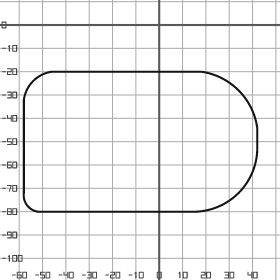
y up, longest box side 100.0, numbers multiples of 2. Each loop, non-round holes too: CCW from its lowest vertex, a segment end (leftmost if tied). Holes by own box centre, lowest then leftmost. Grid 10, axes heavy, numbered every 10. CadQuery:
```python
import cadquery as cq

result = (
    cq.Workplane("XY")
    .moveTo(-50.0, -80.0)
    .lineTo(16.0, -80.0)
    .threePointArc((34.0, -72.0), (42.0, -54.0))
    .lineTo(42.0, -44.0)
    .threePointArc((34.0, -28.0), (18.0, -20.0))
    .lineTo(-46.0, -20.0)
    .threePointArc((-54.0, -24.0), (-58.0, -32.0))
    .lineTo(-58.0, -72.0)
    .threePointArc((-56.0, -78.0), (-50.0, -80.0))
    .close()
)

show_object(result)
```